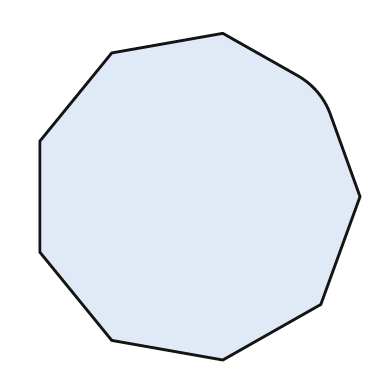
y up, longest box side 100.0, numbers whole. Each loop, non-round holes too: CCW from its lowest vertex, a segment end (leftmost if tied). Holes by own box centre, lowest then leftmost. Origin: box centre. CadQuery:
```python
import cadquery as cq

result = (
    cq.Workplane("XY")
    .moveTo(7.0, -50.0)
    .lineTo(37.0, -33.0)
    .lineTo(49.0, 0.0)
    .lineTo(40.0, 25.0)
    .threePointArc((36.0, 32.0), (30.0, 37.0))
    .lineTo(7.0, 50.0)
    .lineTo(-27.0, 44.0)
    .lineTo(-49.0, 17.0)
    .lineTo(-49.0, -17.0)
    .lineTo(-27.0, -44.0)
    .close()
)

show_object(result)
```